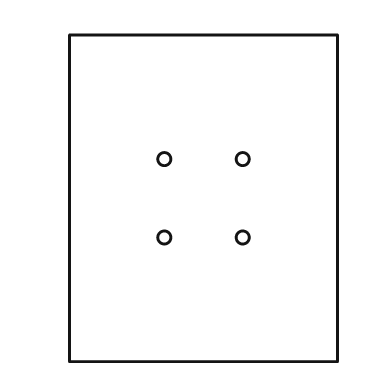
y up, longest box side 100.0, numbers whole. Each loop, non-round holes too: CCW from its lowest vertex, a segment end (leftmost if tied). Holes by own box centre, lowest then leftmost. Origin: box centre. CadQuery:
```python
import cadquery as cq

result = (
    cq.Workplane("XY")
    .moveTo(-41.0, -50.0)
    .lineTo(41.0, -50.0)
    .lineTo(41.0, 50.0)
    .lineTo(-41.0, 50.0)
    .close()
    .moveTo(-12.0, -12.0)
    .circle(2.0)
    .moveTo(12.0, -12.0)
    .circle(2.0)
    .moveTo(-12.0, 12.0)
    .circle(2.0)
    .moveTo(12.0, 12.0)
    .circle(2.0)
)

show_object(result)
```